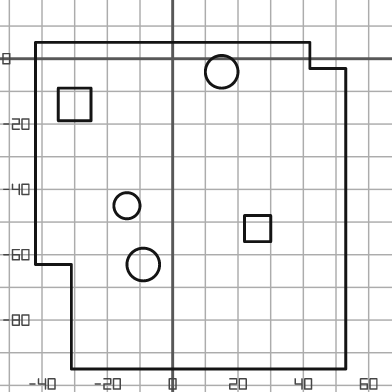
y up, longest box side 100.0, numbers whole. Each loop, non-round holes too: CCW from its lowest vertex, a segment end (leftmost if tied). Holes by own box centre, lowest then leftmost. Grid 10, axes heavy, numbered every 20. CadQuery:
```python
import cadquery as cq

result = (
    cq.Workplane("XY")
    .moveTo(-31.0, -95.0)
    .lineTo(53.0, -95.0)
    .lineTo(53.0, -3.0)
    .lineTo(42.0, -3.0)
    .lineTo(42.0, 5.0)
    .lineTo(-42.0, 5.0)
    .lineTo(-42.0, -63.0)
    .lineTo(-31.0, -63.0)
    .close()
    .moveTo(-9.0, -63.0)
    .circle(5.0)
    .moveTo(22.0, -56.0)
    .lineTo(30.0, -56.0)
    .lineTo(30.0, -48.0)
    .lineTo(22.0, -48.0)
    .close()
    .moveTo(-14.0, -45.0)
    .circle(4.0)
    .moveTo(-35.0, -19.0)
    .lineTo(-25.0, -19.0)
    .lineTo(-25.0, -9.0)
    .lineTo(-35.0, -9.0)
    .close()
    .moveTo(15.0, -4.0)
    .circle(5.0)
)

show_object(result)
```